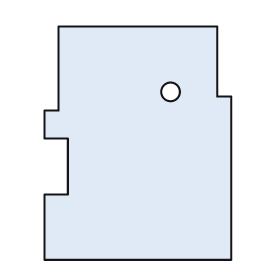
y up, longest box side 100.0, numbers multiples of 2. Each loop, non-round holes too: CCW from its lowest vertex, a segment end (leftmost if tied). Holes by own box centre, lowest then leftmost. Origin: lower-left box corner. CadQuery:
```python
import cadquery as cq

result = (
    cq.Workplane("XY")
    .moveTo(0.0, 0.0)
    .lineTo(80.0, 0.0)
    .lineTo(80.0, 70.0)
    .lineTo(74.0, 70.0)
    .lineTo(74.0, 100.0)
    .lineTo(6.0, 100.0)
    .lineTo(6.0, 64.0)
    .lineTo(0.0, 64.0)
    .lineTo(0.0, 52.0)
    .lineTo(10.0, 52.0)
    .lineTo(10.0, 28.0)
    .lineTo(0.0, 28.0)
    .close()
    .moveTo(54.0, 72.0)
    .circle(4.0)
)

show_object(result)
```